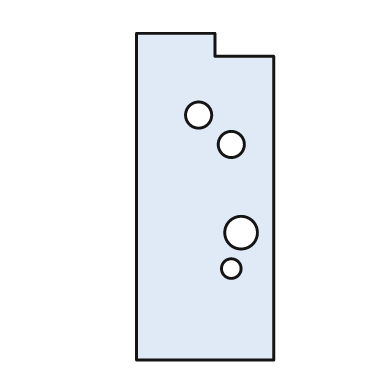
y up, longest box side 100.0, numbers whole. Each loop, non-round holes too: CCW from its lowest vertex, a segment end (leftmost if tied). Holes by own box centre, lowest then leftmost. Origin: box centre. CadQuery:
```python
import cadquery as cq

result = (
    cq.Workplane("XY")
    .moveTo(-21.0, -50.0)
    .lineTo(21.0, -50.0)
    .lineTo(21.0, 43.0)
    .lineTo(3.0, 43.0)
    .lineTo(3.0, 50.0)
    .lineTo(-21.0, 50.0)
    .close()
    .moveTo(8.0, -22.0)
    .circle(3.0)
    .moveTo(11.0, -11.0)
    .circle(5.0)
    .moveTo(8.0, 16.0)
    .circle(4.0)
    .moveTo(-2.0, 25.0)
    .circle(4.0)
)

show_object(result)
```